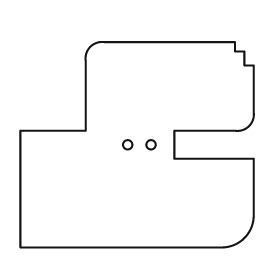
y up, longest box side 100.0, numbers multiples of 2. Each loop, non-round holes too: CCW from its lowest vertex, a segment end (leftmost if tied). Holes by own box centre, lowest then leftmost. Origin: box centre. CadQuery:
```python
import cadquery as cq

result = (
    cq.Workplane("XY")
    .moveTo(-50.0, -44.0)
    .lineTo(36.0, -44.0)
    .threePointArc((46.0, -40.0), (50.0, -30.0))
    .lineTo(50.0, -6.0)
    .lineTo(16.0, -6.0)
    .lineTo(16.0, 6.0)
    .lineTo(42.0, 6.0)
    .threePointArc((48.0, 8.0), (50.0, 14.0))
    .lineTo(50.0, 34.0)
    .lineTo(46.0, 34.0)
    .lineTo(46.0, 40.0)
    .lineTo(42.0, 40.0)
    .lineTo(42.0, 44.0)
    .lineTo(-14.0, 44.0)
    .threePointArc((-20.0, 42.0), (-22.0, 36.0))
    .lineTo(-22.0, 6.0)
    .lineTo(-50.0, 6.0)
    .close()
    .moveTo(-4.0, 0.0)
    .circle(2.0)
    .moveTo(6.0, 0.0)
    .circle(2.0)
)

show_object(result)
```